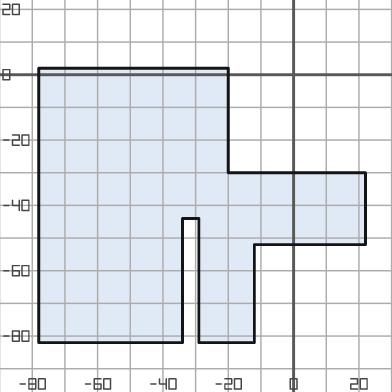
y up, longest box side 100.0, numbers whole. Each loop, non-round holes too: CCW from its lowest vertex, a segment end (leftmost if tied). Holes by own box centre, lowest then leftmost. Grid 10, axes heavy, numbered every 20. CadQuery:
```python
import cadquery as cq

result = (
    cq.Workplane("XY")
    .moveTo(-78.0, -82.0)
    .lineTo(-34.0, -82.0)
    .lineTo(-34.0, -44.0)
    .lineTo(-29.0, -44.0)
    .lineTo(-29.0, -82.0)
    .lineTo(-12.0, -82.0)
    .lineTo(-12.0, -52.0)
    .lineTo(22.0, -52.0)
    .lineTo(22.0, -30.0)
    .lineTo(-20.0, -30.0)
    .lineTo(-20.0, 2.0)
    .lineTo(-78.0, 2.0)
    .close()
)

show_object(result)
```